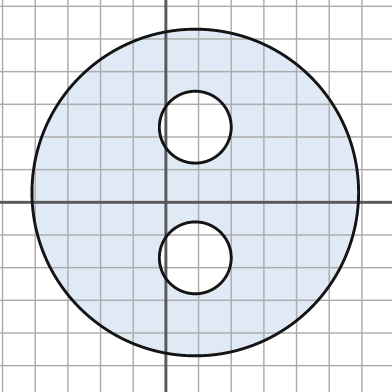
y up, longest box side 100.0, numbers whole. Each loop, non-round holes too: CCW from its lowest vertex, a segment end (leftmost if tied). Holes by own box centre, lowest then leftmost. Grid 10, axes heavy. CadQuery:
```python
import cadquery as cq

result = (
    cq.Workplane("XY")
    .moveTo(9.0, 3.0)
    .circle(50.0)
    .moveTo(9.0, -17.0)
    .circle(11.0)
    .moveTo(9.0, 23.0)
    .circle(11.0)
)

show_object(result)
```